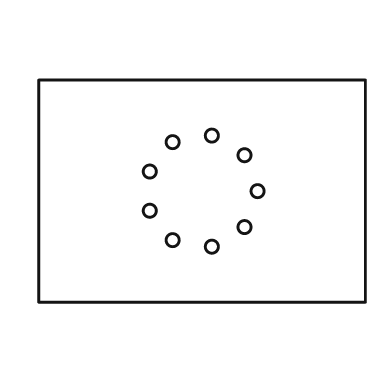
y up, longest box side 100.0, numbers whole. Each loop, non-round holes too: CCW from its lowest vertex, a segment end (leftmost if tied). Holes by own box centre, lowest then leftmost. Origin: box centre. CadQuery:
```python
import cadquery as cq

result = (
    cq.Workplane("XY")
    .moveTo(-50.0, -34.0)
    .lineTo(50.0, -34.0)
    .lineTo(50.0, 34.0)
    .lineTo(-50.0, 34.0)
    .close()
    .moveTo(3.0, -17.0)
    .circle(2.0)
    .moveTo(-9.0, -15.0)
    .circle(2.0)
    .moveTo(13.0, -11.0)
    .circle(2.0)
    .moveTo(-16.0, -6.0)
    .circle(2.0)
    .moveTo(17.0, 0.0)
    .circle(2.0)
    .moveTo(-16.0, 6.0)
    .circle(2.0)
    .moveTo(13.0, 11.0)
    .circle(2.0)
    .moveTo(-9.0, 15.0)
    .circle(2.0)
    .moveTo(3.0, 17.0)
    .circle(2.0)
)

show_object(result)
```